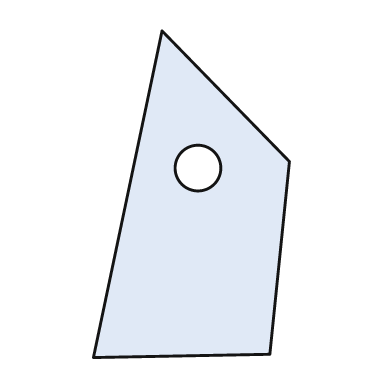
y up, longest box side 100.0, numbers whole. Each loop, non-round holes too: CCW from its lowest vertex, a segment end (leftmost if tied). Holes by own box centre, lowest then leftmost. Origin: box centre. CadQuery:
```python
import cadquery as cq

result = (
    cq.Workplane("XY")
    .moveTo(-30.0, -50.0)
    .lineTo(24.0, -49.0)
    .lineTo(30.0, 10.0)
    .lineTo(-9.0, 50.0)
    .close()
    .moveTo(2.0, 8.0)
    .circle(7.0)
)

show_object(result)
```